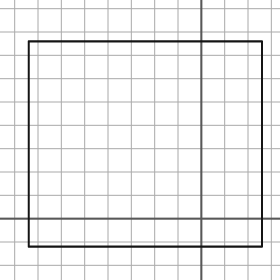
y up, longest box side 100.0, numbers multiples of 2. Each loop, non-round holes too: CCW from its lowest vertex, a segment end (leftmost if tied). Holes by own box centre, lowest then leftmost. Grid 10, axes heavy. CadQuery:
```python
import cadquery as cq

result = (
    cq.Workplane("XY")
    .moveTo(-74.0, -12.0)
    .lineTo(26.0, -12.0)
    .lineTo(26.0, 76.0)
    .lineTo(-74.0, 76.0)
    .close()
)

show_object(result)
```